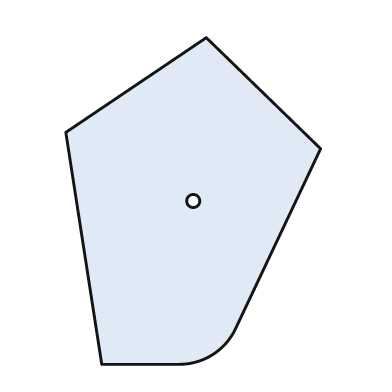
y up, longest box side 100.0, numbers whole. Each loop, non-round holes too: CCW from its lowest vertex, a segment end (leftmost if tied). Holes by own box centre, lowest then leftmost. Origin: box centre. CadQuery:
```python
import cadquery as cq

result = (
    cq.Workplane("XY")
    .moveTo(-28.0, -50.0)
    .lineTo(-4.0, -50.0)
    .threePointArc((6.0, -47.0), (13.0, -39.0))
    .lineTo(39.0, 16.0)
    .lineTo(4.0, 50.0)
    .lineTo(-39.0, 21.0)
    .close()
    .moveTo(0.0, 0.0)
    .circle(2.0)
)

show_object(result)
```